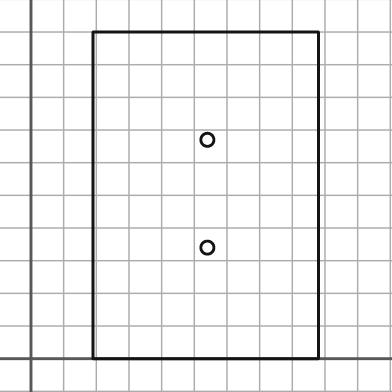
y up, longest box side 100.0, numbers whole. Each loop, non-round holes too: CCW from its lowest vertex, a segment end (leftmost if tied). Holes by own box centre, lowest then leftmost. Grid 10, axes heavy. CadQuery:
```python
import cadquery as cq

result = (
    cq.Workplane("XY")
    .moveTo(19.0, 0.0)
    .lineTo(88.0, 0.0)
    .lineTo(88.0, 100.0)
    .lineTo(19.0, 100.0)
    .close()
    .moveTo(54.0, 34.0)
    .circle(2.0)
    .moveTo(54.0, 67.0)
    .circle(2.0)
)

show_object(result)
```